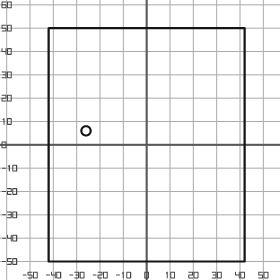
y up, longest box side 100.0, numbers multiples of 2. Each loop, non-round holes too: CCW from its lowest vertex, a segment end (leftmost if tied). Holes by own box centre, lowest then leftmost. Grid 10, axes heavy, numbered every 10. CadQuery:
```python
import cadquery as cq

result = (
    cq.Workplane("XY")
    .moveTo(-42.0, -50.0)
    .lineTo(42.0, -50.0)
    .lineTo(42.0, 50.0)
    .lineTo(-42.0, 50.0)
    .close()
    .moveTo(-26.0, 6.0)
    .circle(2.0)
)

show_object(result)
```